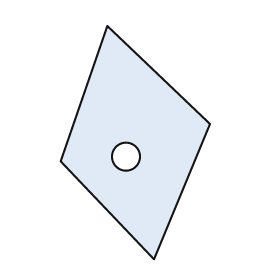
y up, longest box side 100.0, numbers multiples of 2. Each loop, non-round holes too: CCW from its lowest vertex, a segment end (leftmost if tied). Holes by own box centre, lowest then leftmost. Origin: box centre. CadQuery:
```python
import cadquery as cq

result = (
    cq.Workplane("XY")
    .moveTo(8.0, -50.0)
    .lineTo(32.0, 8.0)
    .lineTo(-12.0, 50.0)
    .lineTo(-32.0, -8.0)
    .close()
    .moveTo(-4.0, -6.0)
    .circle(6.0)
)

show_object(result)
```